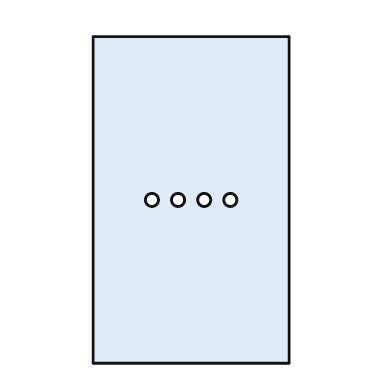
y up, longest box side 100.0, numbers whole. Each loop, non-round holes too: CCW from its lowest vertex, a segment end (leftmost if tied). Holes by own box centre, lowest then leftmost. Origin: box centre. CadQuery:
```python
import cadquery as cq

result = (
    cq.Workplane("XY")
    .moveTo(-30.0, -50.0)
    .lineTo(30.0, -50.0)
    .lineTo(30.0, 50.0)
    .lineTo(-30.0, 50.0)
    .close()
    .moveTo(-12.0, 0.0)
    .circle(2.0)
    .moveTo(-4.0, 0.0)
    .circle(2.0)
    .moveTo(4.0, 0.0)
    .circle(2.0)
    .moveTo(12.0, 0.0)
    .circle(2.0)
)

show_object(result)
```